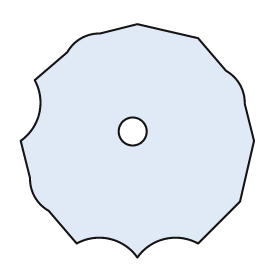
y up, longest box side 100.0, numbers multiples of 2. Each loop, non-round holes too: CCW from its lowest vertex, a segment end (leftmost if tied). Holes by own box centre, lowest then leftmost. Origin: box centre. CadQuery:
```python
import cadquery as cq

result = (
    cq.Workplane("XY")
    .moveTo(0.0, -50.0)
    .threePointArc((12.0, -42.0), (26.0, -44.0))
    .lineTo(44.0, -26.0)
    .lineTo(50.0, 0.0)
    .lineTo(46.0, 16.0)
    .threePointArc((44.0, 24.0), (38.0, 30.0))
    .lineTo(26.0, 44.0)
    .lineTo(0.0, 50.0)
    .lineTo(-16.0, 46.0)
    .threePointArc((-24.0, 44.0), (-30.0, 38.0))
    .lineTo(-44.0, 26.0)
    .threePointArc((-42.0, 12.0), (-50.0, 0.0))
    .lineTo(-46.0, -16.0)
    .threePointArc((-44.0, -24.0), (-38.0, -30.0))
    .lineTo(-26.0, -44.0)
    .threePointArc((-12.0, -42.0), (0.0, -50.0))
    .close()
    .moveTo(-2.0, 4.0)
    .circle(6.0)
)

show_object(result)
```